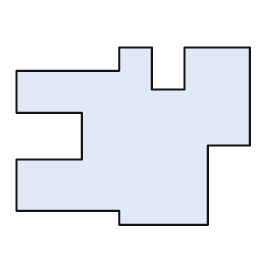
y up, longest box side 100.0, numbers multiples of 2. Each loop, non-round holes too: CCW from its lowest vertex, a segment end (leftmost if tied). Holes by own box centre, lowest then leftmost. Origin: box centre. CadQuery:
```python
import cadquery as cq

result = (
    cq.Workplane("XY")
    .moveTo(-6.0, -38.0)
    .lineTo(32.0, -38.0)
    .lineTo(32.0, -4.0)
    .lineTo(50.0, -4.0)
    .lineTo(50.0, 38.0)
    .lineTo(22.0, 38.0)
    .lineTo(22.0, 20.0)
    .lineTo(8.0, 20.0)
    .lineTo(8.0, 38.0)
    .lineTo(-6.0, 38.0)
    .lineTo(-6.0, 28.0)
    .lineTo(-50.0, 28.0)
    .lineTo(-50.0, 10.0)
    .lineTo(-22.0, 10.0)
    .lineTo(-22.0, -10.0)
    .lineTo(-50.0, -10.0)
    .lineTo(-50.0, -32.0)
    .lineTo(-6.0, -32.0)
    .close()
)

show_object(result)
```